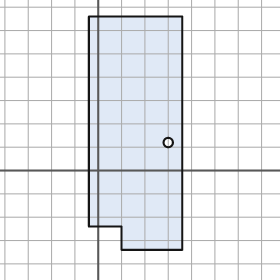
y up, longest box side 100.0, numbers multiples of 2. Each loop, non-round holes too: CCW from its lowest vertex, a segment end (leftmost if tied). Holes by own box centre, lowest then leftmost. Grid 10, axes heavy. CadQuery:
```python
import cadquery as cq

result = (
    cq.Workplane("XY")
    .moveTo(10.0, -34.0)
    .lineTo(36.0, -34.0)
    .lineTo(36.0, 66.0)
    .lineTo(-4.0, 66.0)
    .lineTo(-4.0, -24.0)
    .lineTo(10.0, -24.0)
    .close()
    .moveTo(30.0, 12.0)
    .circle(2.0)
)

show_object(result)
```